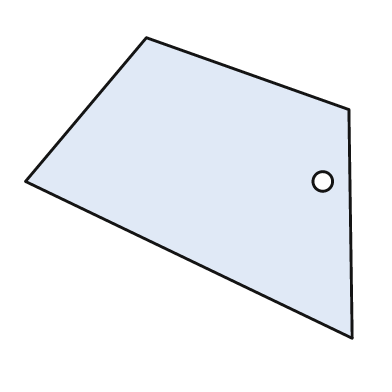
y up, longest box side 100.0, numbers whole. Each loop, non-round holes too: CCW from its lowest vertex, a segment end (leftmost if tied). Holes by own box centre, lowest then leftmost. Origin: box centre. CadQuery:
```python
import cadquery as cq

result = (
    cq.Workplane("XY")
    .moveTo(50.0, -46.0)
    .lineTo(49.0, 24.0)
    .lineTo(-13.0, 46.0)
    .lineTo(-50.0, 2.0)
    .close()
    .moveTo(41.0, 2.0)
    .circle(3.0)
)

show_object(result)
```